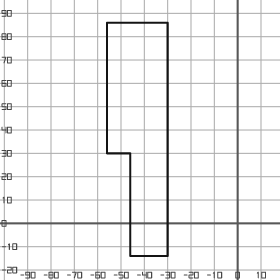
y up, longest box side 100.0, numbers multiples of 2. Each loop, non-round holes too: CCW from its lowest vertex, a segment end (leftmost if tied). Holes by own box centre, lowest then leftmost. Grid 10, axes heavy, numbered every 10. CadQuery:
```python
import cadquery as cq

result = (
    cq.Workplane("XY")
    .moveTo(-46.0, -14.0)
    .lineTo(-30.0, -14.0)
    .lineTo(-30.0, 86.0)
    .lineTo(-56.0, 86.0)
    .lineTo(-56.0, 30.0)
    .lineTo(-46.0, 30.0)
    .close()
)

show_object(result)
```